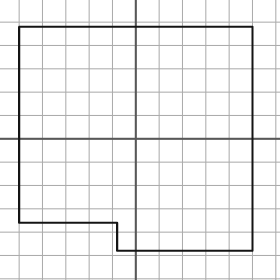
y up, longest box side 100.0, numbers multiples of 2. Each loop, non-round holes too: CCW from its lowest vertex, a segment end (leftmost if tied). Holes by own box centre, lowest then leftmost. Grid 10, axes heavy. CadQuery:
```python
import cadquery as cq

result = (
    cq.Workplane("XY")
    .moveTo(-8.0, -48.0)
    .lineTo(50.0, -48.0)
    .lineTo(50.0, 48.0)
    .lineTo(-50.0, 48.0)
    .lineTo(-50.0, -36.0)
    .lineTo(-8.0, -36.0)
    .close()
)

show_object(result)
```